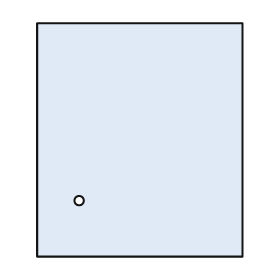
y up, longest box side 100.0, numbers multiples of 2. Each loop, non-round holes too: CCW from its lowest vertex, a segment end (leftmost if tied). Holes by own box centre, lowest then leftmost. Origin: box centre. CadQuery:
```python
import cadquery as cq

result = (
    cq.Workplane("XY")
    .moveTo(-44.0, -50.0)
    .lineTo(44.0, -50.0)
    .lineTo(44.0, 50.0)
    .lineTo(-44.0, 50.0)
    .close()
    .moveTo(-26.0, -26.0)
    .circle(2.0)
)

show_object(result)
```